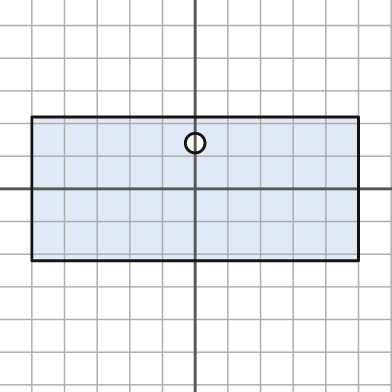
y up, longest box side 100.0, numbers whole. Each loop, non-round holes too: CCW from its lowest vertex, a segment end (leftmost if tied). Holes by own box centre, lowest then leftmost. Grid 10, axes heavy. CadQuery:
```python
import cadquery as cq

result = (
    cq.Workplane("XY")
    .moveTo(-50.0, -22.0)
    .lineTo(50.0, -22.0)
    .lineTo(50.0, 22.0)
    .lineTo(-50.0, 22.0)
    .close()
    .moveTo(0.0, 14.0)
    .circle(3.0)
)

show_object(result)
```